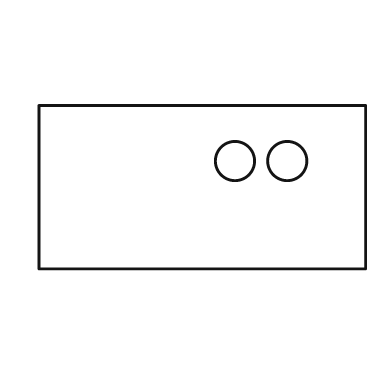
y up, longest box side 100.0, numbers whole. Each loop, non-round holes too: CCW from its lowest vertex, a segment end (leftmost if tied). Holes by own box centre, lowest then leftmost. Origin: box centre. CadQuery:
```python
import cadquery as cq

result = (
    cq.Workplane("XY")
    .moveTo(-50.0, -25.0)
    .lineTo(50.0, -25.0)
    .lineTo(50.0, 25.0)
    .lineTo(-50.0, 25.0)
    .close()
    .moveTo(10.0, 8.0)
    .circle(6.0)
    .moveTo(26.0, 8.0)
    .circle(6.0)
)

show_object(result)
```